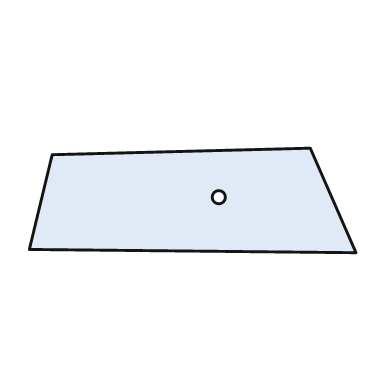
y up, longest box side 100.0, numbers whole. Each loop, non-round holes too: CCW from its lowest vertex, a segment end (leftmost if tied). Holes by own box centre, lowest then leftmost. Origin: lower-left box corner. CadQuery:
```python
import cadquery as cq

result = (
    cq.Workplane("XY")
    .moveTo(100.0, 0.0)
    .lineTo(86.0, 32.0)
    .lineTo(7.0, 30.0)
    .lineTo(0.0, 1.0)
    .close()
    .moveTo(58.0, 17.0)
    .circle(2.0)
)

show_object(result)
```